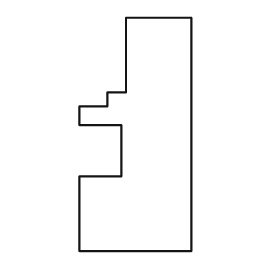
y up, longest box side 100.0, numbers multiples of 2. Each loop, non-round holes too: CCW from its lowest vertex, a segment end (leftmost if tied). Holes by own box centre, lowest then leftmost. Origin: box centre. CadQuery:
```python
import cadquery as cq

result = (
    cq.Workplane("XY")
    .moveTo(-24.0, -50.0)
    .lineTo(24.0, -50.0)
    .lineTo(24.0, 50.0)
    .lineTo(-4.0, 50.0)
    .lineTo(-4.0, 18.0)
    .lineTo(-12.0, 18.0)
    .lineTo(-12.0, 12.0)
    .lineTo(-24.0, 12.0)
    .lineTo(-24.0, 4.0)
    .lineTo(-6.0, 4.0)
    .lineTo(-6.0, -18.0)
    .lineTo(-24.0, -18.0)
    .close()
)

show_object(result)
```